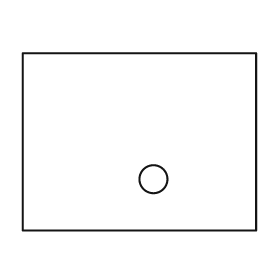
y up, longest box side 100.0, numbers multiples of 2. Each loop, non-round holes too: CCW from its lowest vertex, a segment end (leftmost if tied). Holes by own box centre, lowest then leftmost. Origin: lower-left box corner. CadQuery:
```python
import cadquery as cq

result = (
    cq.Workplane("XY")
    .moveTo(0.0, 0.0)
    .lineTo(100.0, 0.0)
    .lineTo(100.0, 76.0)
    .lineTo(0.0, 76.0)
    .close()
    .moveTo(56.0, 22.0)
    .circle(6.0)
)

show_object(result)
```